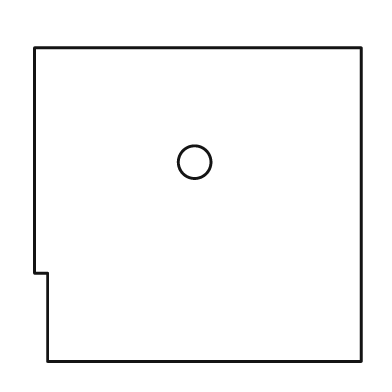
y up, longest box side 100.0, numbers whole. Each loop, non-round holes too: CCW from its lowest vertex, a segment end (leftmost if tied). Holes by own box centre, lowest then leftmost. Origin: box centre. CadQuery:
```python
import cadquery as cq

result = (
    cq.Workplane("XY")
    .moveTo(-46.0, -48.0)
    .lineTo(50.0, -48.0)
    .lineTo(50.0, 48.0)
    .lineTo(-50.0, 48.0)
    .lineTo(-50.0, -21.0)
    .lineTo(-46.0, -21.0)
    .close()
    .moveTo(-1.0, 13.0)
    .circle(5.0)
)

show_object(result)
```